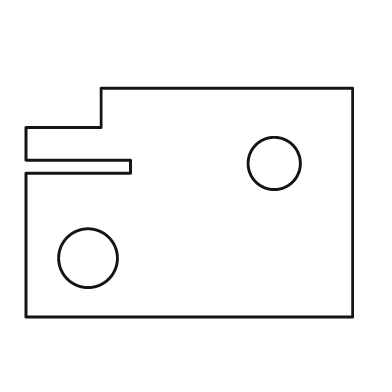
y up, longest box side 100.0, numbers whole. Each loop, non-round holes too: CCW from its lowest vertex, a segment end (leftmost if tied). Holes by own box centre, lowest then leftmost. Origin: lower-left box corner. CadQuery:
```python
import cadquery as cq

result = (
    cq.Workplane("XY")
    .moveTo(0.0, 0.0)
    .lineTo(100.0, 0.0)
    .lineTo(100.0, 70.0)
    .lineTo(23.0, 70.0)
    .lineTo(23.0, 58.0)
    .lineTo(0.0, 58.0)
    .lineTo(0.0, 48.0)
    .lineTo(32.0, 48.0)
    .lineTo(32.0, 44.0)
    .lineTo(0.0, 44.0)
    .close()
    .moveTo(19.0, 18.0)
    .circle(9.0)
    .moveTo(76.0, 47.0)
    .circle(8.0)
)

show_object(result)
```